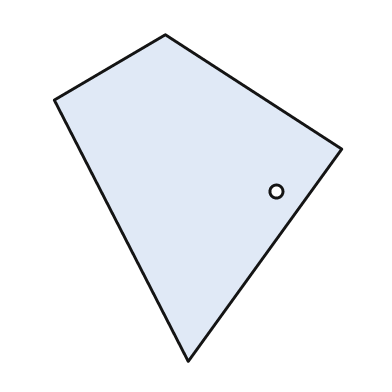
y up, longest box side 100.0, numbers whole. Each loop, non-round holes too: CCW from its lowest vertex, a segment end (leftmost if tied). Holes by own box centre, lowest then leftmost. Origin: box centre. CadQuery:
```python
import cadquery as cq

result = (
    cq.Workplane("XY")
    .moveTo(-3.0, -50.0)
    .lineTo(44.0, 15.0)
    .lineTo(-10.0, 50.0)
    .lineTo(-44.0, 30.0)
    .close()
    .moveTo(24.0, 2.0)
    .circle(2.0)
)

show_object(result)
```